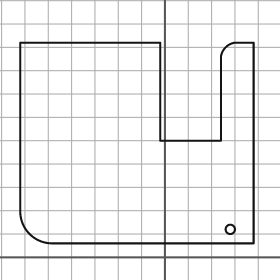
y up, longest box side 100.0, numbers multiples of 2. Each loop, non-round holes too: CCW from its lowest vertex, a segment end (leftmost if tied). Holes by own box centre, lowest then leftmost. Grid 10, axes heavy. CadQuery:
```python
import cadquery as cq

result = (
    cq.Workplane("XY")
    .moveTo(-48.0, 6.0)
    .lineTo(38.0, 6.0)
    .lineTo(38.0, 92.0)
    .lineTo(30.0, 92.0)
    .threePointArc((26.0, 90.0), (24.0, 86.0))
    .lineTo(24.0, 50.0)
    .lineTo(-2.0, 50.0)
    .lineTo(-2.0, 92.0)
    .lineTo(-62.0, 92.0)
    .lineTo(-62.0, 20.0)
    .threePointArc((-58.0, 10.0), (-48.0, 6.0))
    .close()
    .moveTo(28.0, 12.0)
    .circle(2.0)
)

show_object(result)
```